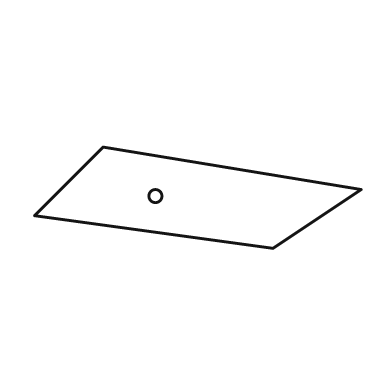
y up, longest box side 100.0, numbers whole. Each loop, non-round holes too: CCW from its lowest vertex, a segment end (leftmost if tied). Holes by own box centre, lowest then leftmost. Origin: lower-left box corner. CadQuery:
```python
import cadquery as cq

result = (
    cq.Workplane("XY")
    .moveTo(73.0, 0.0)
    .lineTo(100.0, 18.0)
    .lineTo(21.0, 31.0)
    .lineTo(0.0, 10.0)
    .close()
    .moveTo(37.0, 16.0)
    .circle(2.0)
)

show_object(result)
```